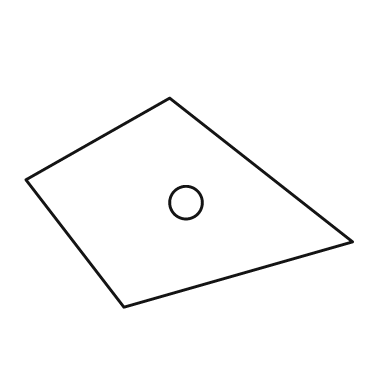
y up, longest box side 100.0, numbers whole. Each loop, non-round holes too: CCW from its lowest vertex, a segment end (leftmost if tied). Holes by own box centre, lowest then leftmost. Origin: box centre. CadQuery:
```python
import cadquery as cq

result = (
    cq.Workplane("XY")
    .moveTo(-20.0, -32.0)
    .lineTo(50.0, -12.0)
    .lineTo(-6.0, 32.0)
    .lineTo(-50.0, 7.0)
    .close()
    .moveTo(-1.0, 0.0)
    .circle(5.0)
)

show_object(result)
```